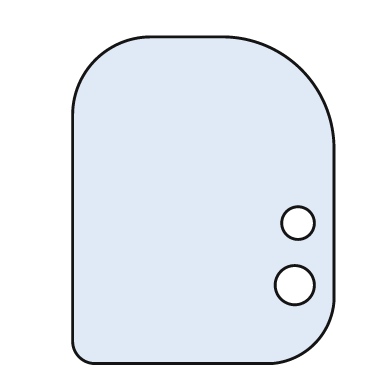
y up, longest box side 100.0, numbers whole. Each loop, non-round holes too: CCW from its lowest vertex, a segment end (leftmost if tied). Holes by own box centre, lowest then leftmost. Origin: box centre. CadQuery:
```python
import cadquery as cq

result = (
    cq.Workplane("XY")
    .moveTo(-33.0, -50.0)
    .lineTo(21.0, -50.0)
    .threePointArc((34.0, -44.0), (40.0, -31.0))
    .lineTo(40.0, 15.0)
    .threePointArc((30.0, 40.0), (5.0, 50.0))
    .lineTo(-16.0, 50.0)
    .threePointArc((-33.0, 43.0), (-40.0, 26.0))
    .lineTo(-40.0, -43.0)
    .threePointArc((-38.0, -48.0), (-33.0, -50.0))
    .close()
    .moveTo(28.0, -26.0)
    .circle(6.0)
    .moveTo(29.0, -7.0)
    .circle(5.0)
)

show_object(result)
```